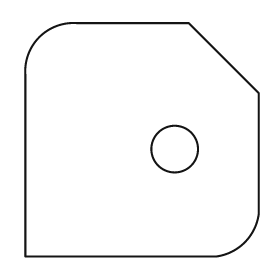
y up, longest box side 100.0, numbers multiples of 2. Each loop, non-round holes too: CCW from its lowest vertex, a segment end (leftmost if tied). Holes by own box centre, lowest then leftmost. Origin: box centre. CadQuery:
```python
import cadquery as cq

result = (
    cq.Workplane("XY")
    .moveTo(-50.0, -50.0)
    .lineTo(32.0, -50.0)
    .threePointArc((44.0, -44.0), (50.0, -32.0))
    .lineTo(50.0, 20.0)
    .lineTo(20.0, 50.0)
    .lineTo(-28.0, 50.0)
    .threePointArc((-44.0, 44.0), (-50.0, 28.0))
    .close()
    .moveTo(14.0, -4.0)
    .circle(10.0)
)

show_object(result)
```